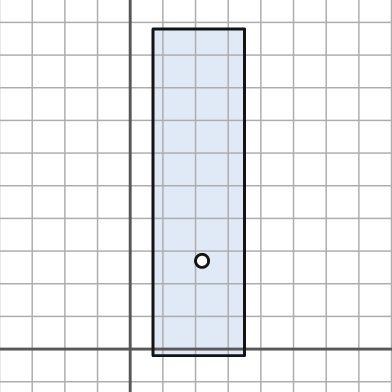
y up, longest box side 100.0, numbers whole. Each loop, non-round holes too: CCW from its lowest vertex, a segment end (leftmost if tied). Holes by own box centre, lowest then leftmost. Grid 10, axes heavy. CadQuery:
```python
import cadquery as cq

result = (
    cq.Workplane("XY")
    .moveTo(7.0, -2.0)
    .lineTo(35.0, -2.0)
    .lineTo(35.0, 98.0)
    .lineTo(7.0, 98.0)
    .close()
    .moveTo(22.0, 27.0)
    .circle(2.0)
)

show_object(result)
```